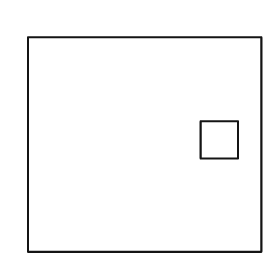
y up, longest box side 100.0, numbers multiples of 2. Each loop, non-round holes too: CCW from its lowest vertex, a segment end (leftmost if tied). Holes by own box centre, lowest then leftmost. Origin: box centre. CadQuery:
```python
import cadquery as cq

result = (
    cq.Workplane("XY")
    .moveTo(-50.0, -46.0)
    .lineTo(50.0, -46.0)
    .lineTo(50.0, 46.0)
    .lineTo(-50.0, 46.0)
    .close()
    .moveTo(24.0, -6.0)
    .lineTo(40.0, -6.0)
    .lineTo(40.0, 10.0)
    .lineTo(24.0, 10.0)
    .close()
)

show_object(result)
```